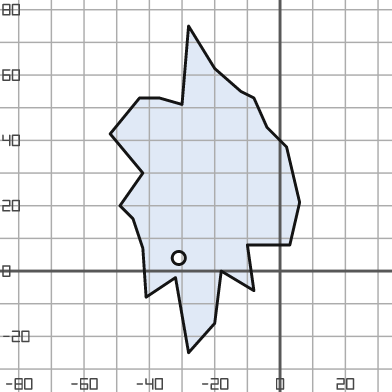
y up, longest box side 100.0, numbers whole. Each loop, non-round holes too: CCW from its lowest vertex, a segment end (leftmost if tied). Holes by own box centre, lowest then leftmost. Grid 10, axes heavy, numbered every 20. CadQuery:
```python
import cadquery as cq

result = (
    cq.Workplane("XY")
    .moveTo(-28.0, -25.0)
    .lineTo(-20.0, -16.0)
    .lineTo(-18.0, 0.0)
    .lineTo(-8.0, -6.0)
    .lineTo(-10.0, 8.0)
    .lineTo(3.0, 8.0)
    .lineTo(6.0, 21.0)
    .lineTo(2.0, 38.0)
    .lineTo(-4.0, 44.0)
    .lineTo(-8.0, 53.0)
    .lineTo(-12.0, 55.0)
    .lineTo(-20.0, 62.0)
    .lineTo(-28.0, 75.0)
    .lineTo(-30.0, 51.0)
    .lineTo(-37.0, 53.0)
    .lineTo(-43.0, 53.0)
    .lineTo(-52.0, 42.0)
    .lineTo(-42.0, 30.0)
    .lineTo(-49.0, 20.0)
    .lineTo(-45.0, 16.0)
    .lineTo(-42.0, 7.0)
    .lineTo(-41.0, -8.0)
    .lineTo(-32.0, -2.0)
    .close()
    .moveTo(-31.0, 4.0)
    .circle(2.0)
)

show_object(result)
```